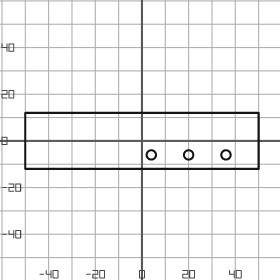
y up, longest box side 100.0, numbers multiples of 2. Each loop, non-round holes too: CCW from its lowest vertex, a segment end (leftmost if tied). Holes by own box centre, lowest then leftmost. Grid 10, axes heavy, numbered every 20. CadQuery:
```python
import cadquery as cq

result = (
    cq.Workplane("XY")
    .moveTo(-50.0, -12.0)
    .lineTo(50.0, -12.0)
    .lineTo(50.0, 12.0)
    .lineTo(-50.0, 12.0)
    .close()
    .moveTo(4.0, -6.0)
    .circle(2.0)
    .moveTo(20.0, -6.0)
    .circle(2.0)
    .moveTo(36.0, -6.0)
    .circle(2.0)
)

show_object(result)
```